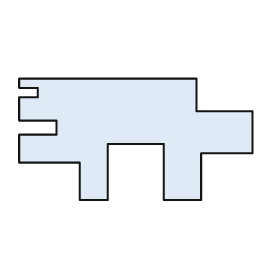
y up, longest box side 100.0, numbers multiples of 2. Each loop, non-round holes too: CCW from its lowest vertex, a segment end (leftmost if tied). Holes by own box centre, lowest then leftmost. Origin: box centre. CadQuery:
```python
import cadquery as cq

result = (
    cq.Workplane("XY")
    .moveTo(-24.0, -26.0)
    .lineTo(-12.0, -26.0)
    .lineTo(-12.0, -2.0)
    .lineTo(12.0, -2.0)
    .lineTo(12.0, -26.0)
    .lineTo(28.0, -26.0)
    .lineTo(28.0, -6.0)
    .lineTo(50.0, -6.0)
    .lineTo(50.0, 12.0)
    .lineTo(26.0, 12.0)
    .lineTo(26.0, 26.0)
    .lineTo(-50.0, 26.0)
    .lineTo(-50.0, 22.0)
    .lineTo(-42.0, 22.0)
    .lineTo(-42.0, 18.0)
    .lineTo(-50.0, 18.0)
    .lineTo(-50.0, 8.0)
    .lineTo(-34.0, 8.0)
    .lineTo(-34.0, 2.0)
    .lineTo(-50.0, 2.0)
    .lineTo(-50.0, -10.0)
    .lineTo(-24.0, -10.0)
    .close()
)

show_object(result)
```